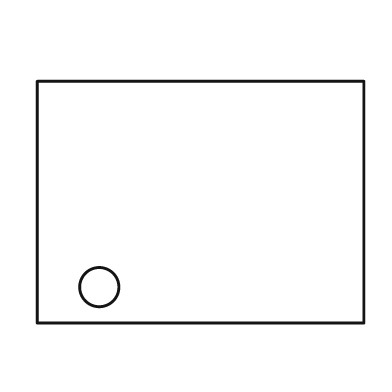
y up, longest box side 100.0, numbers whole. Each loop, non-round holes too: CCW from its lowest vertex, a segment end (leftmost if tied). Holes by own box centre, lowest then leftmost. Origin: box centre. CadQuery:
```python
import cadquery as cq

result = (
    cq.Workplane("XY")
    .moveTo(-50.0, -37.0)
    .lineTo(50.0, -37.0)
    .lineTo(50.0, 37.0)
    .lineTo(-50.0, 37.0)
    .close()
    .moveTo(-31.0, -26.0)
    .circle(6.0)
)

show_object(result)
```